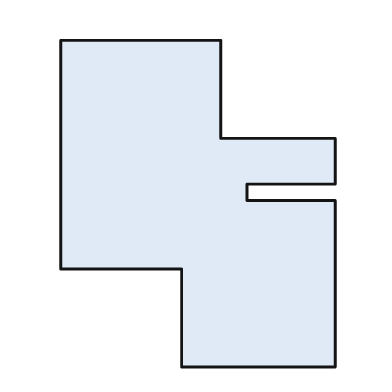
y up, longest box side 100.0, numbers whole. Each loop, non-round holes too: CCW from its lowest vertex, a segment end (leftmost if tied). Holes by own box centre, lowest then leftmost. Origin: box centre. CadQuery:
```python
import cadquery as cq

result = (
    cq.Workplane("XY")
    .moveTo(-5.0, -50.0)
    .lineTo(42.0, -50.0)
    .lineTo(42.0, 1.0)
    .lineTo(15.0, 1.0)
    .lineTo(15.0, 6.0)
    .lineTo(42.0, 6.0)
    .lineTo(42.0, 20.0)
    .lineTo(7.0, 20.0)
    .lineTo(7.0, 50.0)
    .lineTo(-42.0, 50.0)
    .lineTo(-42.0, -20.0)
    .lineTo(-5.0, -20.0)
    .close()
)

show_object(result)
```